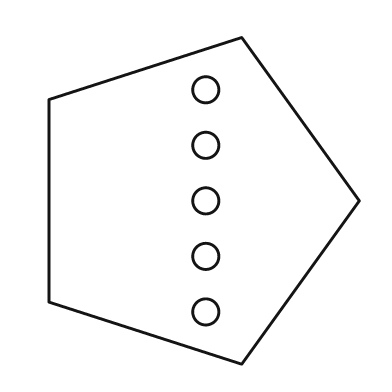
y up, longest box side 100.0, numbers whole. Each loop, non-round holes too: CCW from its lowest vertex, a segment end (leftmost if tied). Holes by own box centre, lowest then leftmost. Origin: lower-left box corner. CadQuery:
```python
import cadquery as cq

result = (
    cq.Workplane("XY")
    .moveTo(59.0, 0.0)
    .lineTo(95.0, 50.0)
    .lineTo(59.0, 100.0)
    .lineTo(0.0, 81.0)
    .lineTo(0.0, 19.0)
    .close()
    .moveTo(48.0, 16.0)
    .circle(4.0)
    .moveTo(48.0, 33.0)
    .circle(4.0)
    .moveTo(48.0, 50.0)
    .circle(4.0)
    .moveTo(48.0, 67.0)
    .circle(4.0)
    .moveTo(48.0, 84.0)
    .circle(4.0)
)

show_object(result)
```